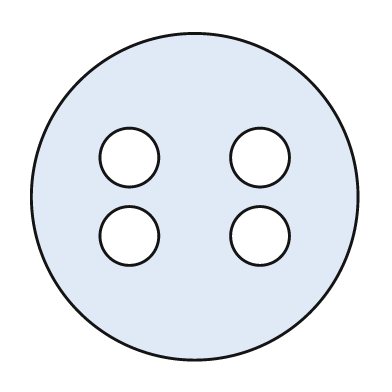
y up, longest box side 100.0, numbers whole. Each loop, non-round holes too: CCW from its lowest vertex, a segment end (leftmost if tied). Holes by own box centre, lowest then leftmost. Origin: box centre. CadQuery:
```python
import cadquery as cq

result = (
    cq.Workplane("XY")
    .moveTo(0.0, 0.0)
    .circle(50.0)
    .moveTo(-20.0, -12.0)
    .circle(9.0)
    .moveTo(20.0, -12.0)
    .circle(9.0)
    .moveTo(-20.0, 12.0)
    .circle(9.0)
    .moveTo(20.0, 12.0)
    .circle(9.0)
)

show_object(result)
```